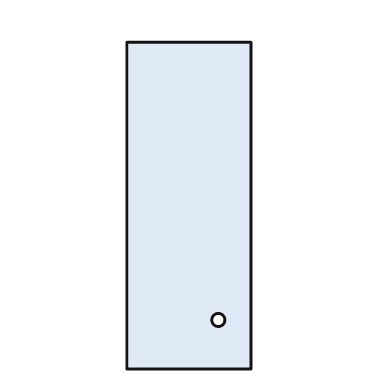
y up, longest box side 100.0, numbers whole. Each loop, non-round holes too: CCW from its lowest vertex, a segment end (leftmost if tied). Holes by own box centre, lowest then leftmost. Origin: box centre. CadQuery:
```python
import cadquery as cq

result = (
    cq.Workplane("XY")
    .moveTo(-19.0, -50.0)
    .lineTo(19.0, -50.0)
    .lineTo(19.0, 50.0)
    .lineTo(-19.0, 50.0)
    .close()
    .moveTo(9.0, -35.0)
    .circle(2.0)
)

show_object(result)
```